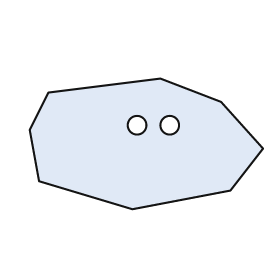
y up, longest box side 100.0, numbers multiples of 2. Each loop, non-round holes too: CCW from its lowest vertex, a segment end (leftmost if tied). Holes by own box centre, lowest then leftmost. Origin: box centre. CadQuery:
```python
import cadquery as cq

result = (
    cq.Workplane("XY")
    .moveTo(-6.0, -28.0)
    .lineTo(36.0, -20.0)
    .lineTo(50.0, -2.0)
    .lineTo(32.0, 18.0)
    .lineTo(6.0, 28.0)
    .lineTo(-42.0, 22.0)
    .lineTo(-50.0, 6.0)
    .lineTo(-46.0, -16.0)
    .close()
    .moveTo(-4.0, 8.0)
    .circle(4.0)
    .moveTo(10.0, 8.0)
    .circle(4.0)
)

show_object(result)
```